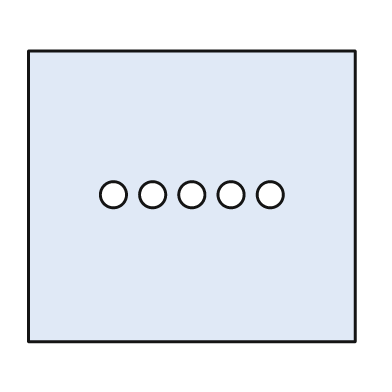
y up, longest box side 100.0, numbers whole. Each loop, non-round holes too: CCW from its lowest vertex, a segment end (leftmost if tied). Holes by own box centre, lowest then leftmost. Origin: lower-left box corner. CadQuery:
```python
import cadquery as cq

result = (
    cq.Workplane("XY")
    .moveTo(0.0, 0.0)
    .lineTo(100.0, 0.0)
    .lineTo(100.0, 89.0)
    .lineTo(0.0, 89.0)
    .close()
    .moveTo(26.0, 45.0)
    .circle(4.0)
    .moveTo(38.0, 45.0)
    .circle(4.0)
    .moveTo(50.0, 45.0)
    .circle(4.0)
    .moveTo(62.0, 45.0)
    .circle(4.0)
    .moveTo(74.0, 45.0)
    .circle(4.0)
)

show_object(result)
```